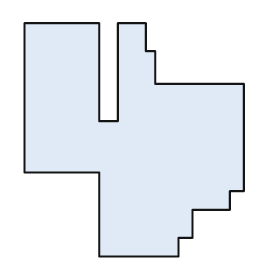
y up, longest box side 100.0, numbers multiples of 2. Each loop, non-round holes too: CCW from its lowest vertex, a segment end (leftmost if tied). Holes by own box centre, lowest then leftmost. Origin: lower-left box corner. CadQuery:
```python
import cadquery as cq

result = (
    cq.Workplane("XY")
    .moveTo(32.0, 0.0)
    .lineTo(66.0, 0.0)
    .lineTo(66.0, 8.0)
    .lineTo(72.0, 8.0)
    .lineTo(72.0, 20.0)
    .lineTo(88.0, 20.0)
    .lineTo(88.0, 28.0)
    .lineTo(94.0, 28.0)
    .lineTo(94.0, 74.0)
    .lineTo(56.0, 74.0)
    .lineTo(56.0, 88.0)
    .lineTo(52.0, 88.0)
    .lineTo(52.0, 100.0)
    .lineTo(40.0, 100.0)
    .lineTo(40.0, 58.0)
    .lineTo(32.0, 58.0)
    .lineTo(32.0, 100.0)
    .lineTo(0.0, 100.0)
    .lineTo(0.0, 36.0)
    .lineTo(32.0, 36.0)
    .close()
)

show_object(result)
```